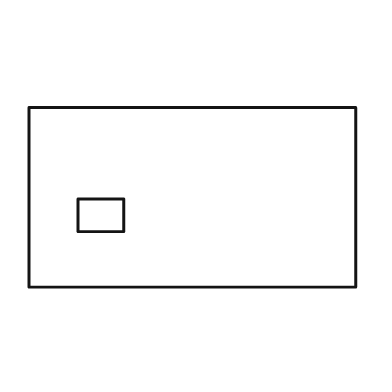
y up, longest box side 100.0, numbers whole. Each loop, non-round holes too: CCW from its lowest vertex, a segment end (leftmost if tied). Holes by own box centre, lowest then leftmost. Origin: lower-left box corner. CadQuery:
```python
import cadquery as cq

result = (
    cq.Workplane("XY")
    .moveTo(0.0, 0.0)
    .lineTo(100.0, 0.0)
    .lineTo(100.0, 55.0)
    .lineTo(0.0, 55.0)
    .close()
    .moveTo(15.0, 17.0)
    .lineTo(29.0, 17.0)
    .lineTo(29.0, 27.0)
    .lineTo(15.0, 27.0)
    .close()
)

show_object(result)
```